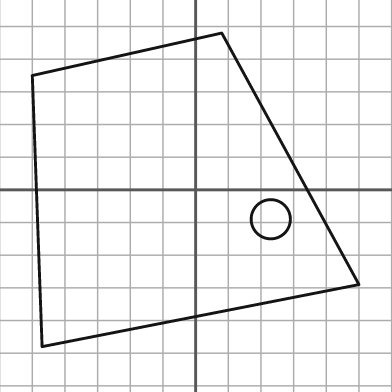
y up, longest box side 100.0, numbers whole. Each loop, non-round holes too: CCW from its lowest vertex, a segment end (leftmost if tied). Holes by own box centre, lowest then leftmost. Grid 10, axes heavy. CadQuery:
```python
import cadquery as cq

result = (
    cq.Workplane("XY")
    .moveTo(-47.0, -48.0)
    .lineTo(50.0, -29.0)
    .lineTo(8.0, 48.0)
    .lineTo(-50.0, 35.0)
    .close()
    .moveTo(23.0, -9.0)
    .circle(6.0)
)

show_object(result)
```